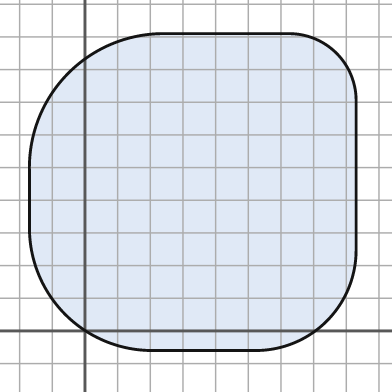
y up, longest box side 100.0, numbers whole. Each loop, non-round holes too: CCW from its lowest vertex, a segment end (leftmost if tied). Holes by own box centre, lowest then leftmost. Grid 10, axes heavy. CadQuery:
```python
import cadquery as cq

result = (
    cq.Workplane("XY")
    .moveTo(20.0, -6.0)
    .lineTo(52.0, -6.0)
    .threePointArc((74.0, 3.0), (83.0, 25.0))
    .lineTo(83.0, 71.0)
    .threePointArc((77.0, 85.0), (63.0, 91.0))
    .lineTo(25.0, 91.0)
    .threePointArc((-5.0, 79.0), (-17.0, 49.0))
    .lineTo(-17.0, 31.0)
    .threePointArc((-6.0, 5.0), (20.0, -6.0))
    .close()
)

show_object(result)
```